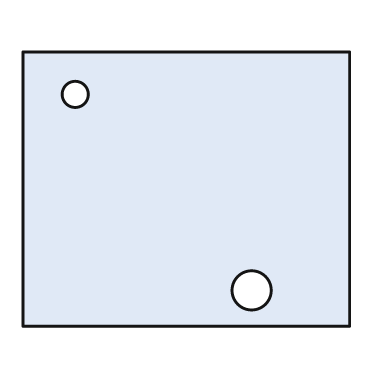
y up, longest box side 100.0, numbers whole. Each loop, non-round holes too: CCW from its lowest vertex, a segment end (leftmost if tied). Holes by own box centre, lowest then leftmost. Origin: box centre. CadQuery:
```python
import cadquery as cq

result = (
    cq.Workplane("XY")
    .moveTo(-50.0, -42.0)
    .lineTo(50.0, -42.0)
    .lineTo(50.0, 42.0)
    .lineTo(-50.0, 42.0)
    .close()
    .moveTo(20.0, -31.0)
    .circle(6.0)
    .moveTo(-34.0, 29.0)
    .circle(4.0)
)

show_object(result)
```